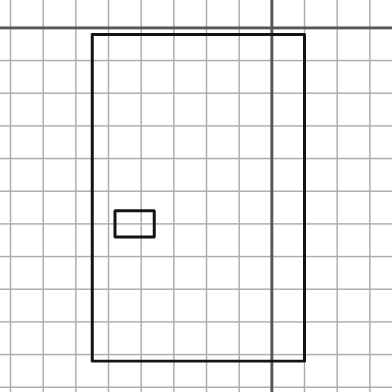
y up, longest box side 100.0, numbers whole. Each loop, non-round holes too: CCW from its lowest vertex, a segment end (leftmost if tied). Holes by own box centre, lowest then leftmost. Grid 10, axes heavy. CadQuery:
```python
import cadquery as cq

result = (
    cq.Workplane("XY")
    .moveTo(-55.0, -102.0)
    .lineTo(10.0, -102.0)
    .lineTo(10.0, -2.0)
    .lineTo(-55.0, -2.0)
    .close()
    .moveTo(-48.0, -64.0)
    .lineTo(-36.0, -64.0)
    .lineTo(-36.0, -56.0)
    .lineTo(-48.0, -56.0)
    .close()
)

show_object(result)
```